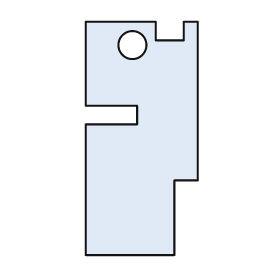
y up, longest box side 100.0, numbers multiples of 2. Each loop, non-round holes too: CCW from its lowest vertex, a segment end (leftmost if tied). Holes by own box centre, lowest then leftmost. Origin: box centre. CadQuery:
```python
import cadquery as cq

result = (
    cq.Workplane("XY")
    .moveTo(-24.0, -50.0)
    .lineTo(14.0, -50.0)
    .lineTo(14.0, -18.0)
    .lineTo(24.0, -18.0)
    .lineTo(24.0, 50.0)
    .lineTo(18.0, 50.0)
    .lineTo(18.0, 42.0)
    .lineTo(6.0, 42.0)
    .lineTo(6.0, 50.0)
    .lineTo(-24.0, 50.0)
    .lineTo(-24.0, 14.0)
    .lineTo(-2.0, 14.0)
    .lineTo(-2.0, 6.0)
    .lineTo(-24.0, 6.0)
    .close()
    .moveTo(-4.0, 40.0)
    .circle(6.0)
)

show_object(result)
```